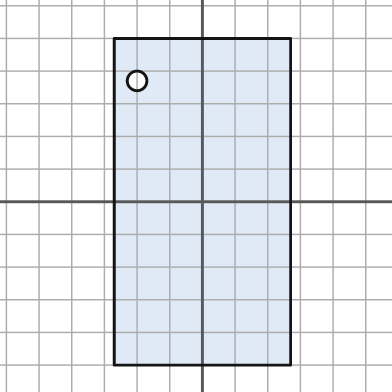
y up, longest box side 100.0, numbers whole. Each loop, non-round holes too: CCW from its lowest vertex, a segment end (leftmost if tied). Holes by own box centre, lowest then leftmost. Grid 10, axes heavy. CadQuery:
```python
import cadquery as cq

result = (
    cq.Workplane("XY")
    .moveTo(-27.0, -50.0)
    .lineTo(27.0, -50.0)
    .lineTo(27.0, 50.0)
    .lineTo(-27.0, 50.0)
    .close()
    .moveTo(-20.0, 37.0)
    .circle(3.0)
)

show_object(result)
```